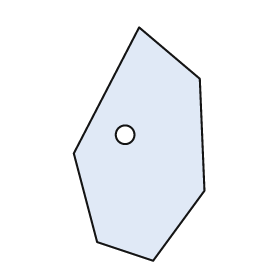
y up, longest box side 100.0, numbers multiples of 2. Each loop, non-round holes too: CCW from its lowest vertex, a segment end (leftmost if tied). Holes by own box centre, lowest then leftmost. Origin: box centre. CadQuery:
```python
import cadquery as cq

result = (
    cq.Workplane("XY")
    .moveTo(6.0, -50.0)
    .lineTo(28.0, -20.0)
    .lineTo(26.0, 28.0)
    .lineTo(0.0, 50.0)
    .lineTo(-28.0, -4.0)
    .lineTo(-18.0, -42.0)
    .close()
    .moveTo(-6.0, 4.0)
    .circle(4.0)
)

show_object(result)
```